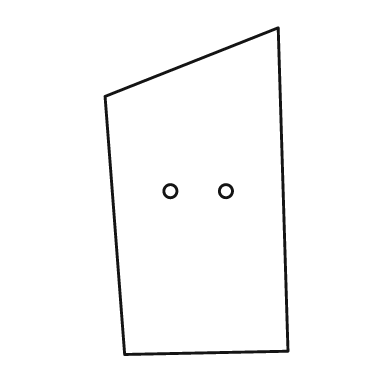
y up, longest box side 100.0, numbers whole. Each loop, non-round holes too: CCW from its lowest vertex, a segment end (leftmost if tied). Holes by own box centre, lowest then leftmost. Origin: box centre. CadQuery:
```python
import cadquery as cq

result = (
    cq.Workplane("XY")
    .moveTo(-22.0, -50.0)
    .lineTo(28.0, -49.0)
    .lineTo(25.0, 50.0)
    .lineTo(-28.0, 29.0)
    .close()
    .moveTo(-8.0, 0.0)
    .circle(2.0)
    .moveTo(9.0, 0.0)
    .circle(2.0)
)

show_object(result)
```